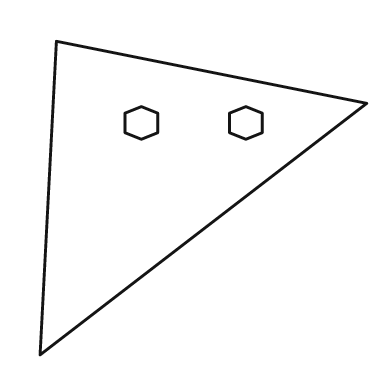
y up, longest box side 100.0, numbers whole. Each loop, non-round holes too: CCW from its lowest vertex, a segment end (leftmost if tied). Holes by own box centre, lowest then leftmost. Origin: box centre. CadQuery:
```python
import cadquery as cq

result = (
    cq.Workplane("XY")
    .moveTo(-50.0, -48.0)
    .lineTo(50.0, 29.0)
    .lineTo(-45.0, 48.0)
    .close()
    .moveTo(-19.0, 18.0)
    .lineTo(-14.0, 20.0)
    .lineTo(-14.0, 26.0)
    .lineTo(-19.0, 28.0)
    .lineTo(-24.0, 26.0)
    .lineTo(-24.0, 20.0)
    .close()
    .moveTo(13.0, 18.0)
    .lineTo(18.0, 20.0)
    .lineTo(18.0, 26.0)
    .lineTo(13.0, 28.0)
    .lineTo(8.0, 26.0)
    .lineTo(8.0, 20.0)
    .close()
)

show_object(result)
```